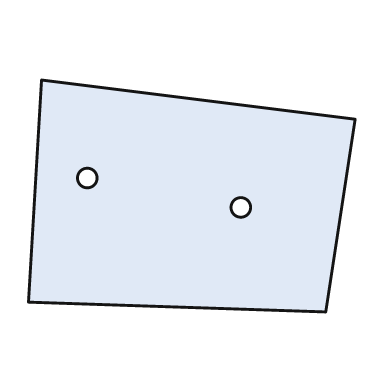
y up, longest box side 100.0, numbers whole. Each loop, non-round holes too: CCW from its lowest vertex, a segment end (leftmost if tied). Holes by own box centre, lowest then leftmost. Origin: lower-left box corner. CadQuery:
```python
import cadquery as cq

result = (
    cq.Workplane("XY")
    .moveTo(91.0, 0.0)
    .lineTo(100.0, 59.0)
    .lineTo(4.0, 71.0)
    .lineTo(0.0, 3.0)
    .close()
    .moveTo(65.0, 32.0)
    .circle(3.0)
    .moveTo(18.0, 41.0)
    .circle(3.0)
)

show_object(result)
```